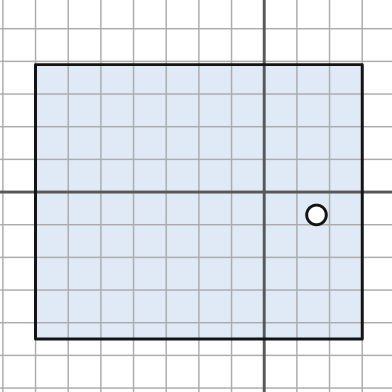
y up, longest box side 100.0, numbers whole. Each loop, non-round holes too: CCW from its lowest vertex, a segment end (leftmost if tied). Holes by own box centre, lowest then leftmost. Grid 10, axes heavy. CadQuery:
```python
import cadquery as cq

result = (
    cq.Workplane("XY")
    .moveTo(-70.0, -45.0)
    .lineTo(30.0, -45.0)
    .lineTo(30.0, 39.0)
    .lineTo(-70.0, 39.0)
    .close()
    .moveTo(16.0, -7.0)
    .circle(3.0)
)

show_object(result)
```